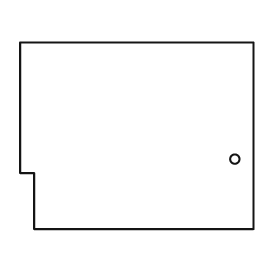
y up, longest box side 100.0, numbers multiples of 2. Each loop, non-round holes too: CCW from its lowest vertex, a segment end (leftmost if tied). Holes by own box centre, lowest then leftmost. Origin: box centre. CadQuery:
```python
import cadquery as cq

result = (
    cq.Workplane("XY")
    .moveTo(-44.0, -40.0)
    .lineTo(50.0, -40.0)
    .lineTo(50.0, 40.0)
    .lineTo(-50.0, 40.0)
    .lineTo(-50.0, -16.0)
    .lineTo(-44.0, -16.0)
    .close()
    .moveTo(42.0, -10.0)
    .circle(2.0)
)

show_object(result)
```